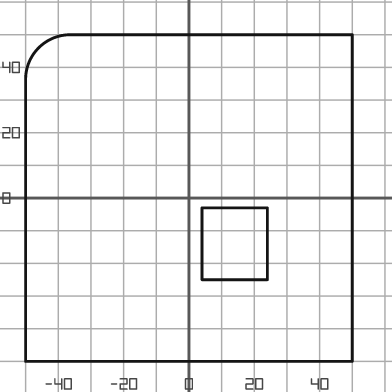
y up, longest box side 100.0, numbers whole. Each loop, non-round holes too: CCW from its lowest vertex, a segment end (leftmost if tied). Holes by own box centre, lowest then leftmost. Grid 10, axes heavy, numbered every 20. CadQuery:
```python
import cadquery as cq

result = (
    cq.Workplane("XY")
    .moveTo(-50.0, -50.0)
    .lineTo(50.0, -50.0)
    .lineTo(50.0, 50.0)
    .lineTo(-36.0, 50.0)
    .threePointArc((-46.0, 46.0), (-50.0, 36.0))
    .close()
    .moveTo(4.0, -25.0)
    .lineTo(24.0, -25.0)
    .lineTo(24.0, -3.0)
    .lineTo(4.0, -3.0)
    .close()
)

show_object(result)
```